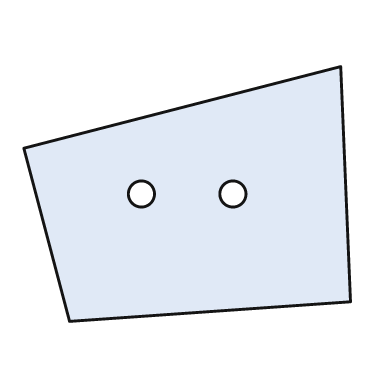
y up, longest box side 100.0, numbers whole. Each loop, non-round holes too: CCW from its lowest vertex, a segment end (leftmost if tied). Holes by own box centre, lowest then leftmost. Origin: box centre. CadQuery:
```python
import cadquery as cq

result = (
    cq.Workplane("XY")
    .moveTo(-36.0, -39.0)
    .lineTo(50.0, -33.0)
    .lineTo(47.0, 39.0)
    .lineTo(-50.0, 14.0)
    .close()
    .moveTo(-14.0, 0.0)
    .circle(4.0)
    .moveTo(14.0, 0.0)
    .circle(4.0)
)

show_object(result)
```